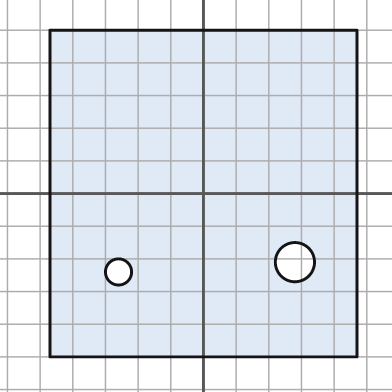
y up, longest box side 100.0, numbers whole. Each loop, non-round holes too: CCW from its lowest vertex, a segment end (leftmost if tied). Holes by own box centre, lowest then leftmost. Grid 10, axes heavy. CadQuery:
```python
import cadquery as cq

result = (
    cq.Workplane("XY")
    .moveTo(-47.0, -50.0)
    .lineTo(47.0, -50.0)
    .lineTo(47.0, 50.0)
    .lineTo(-47.0, 50.0)
    .close()
    .moveTo(-26.0, -24.0)
    .circle(4.0)
    .moveTo(28.0, -21.0)
    .circle(6.0)
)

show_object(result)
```